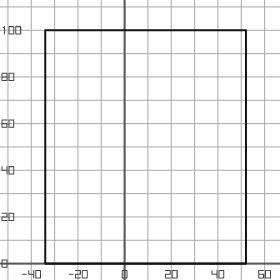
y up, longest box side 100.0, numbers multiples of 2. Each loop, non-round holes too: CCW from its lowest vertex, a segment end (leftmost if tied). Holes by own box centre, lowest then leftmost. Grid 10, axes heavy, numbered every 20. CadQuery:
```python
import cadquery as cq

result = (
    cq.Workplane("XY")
    .moveTo(-34.0, 0.0)
    .lineTo(52.0, 0.0)
    .lineTo(52.0, 100.0)
    .lineTo(-34.0, 100.0)
    .close()
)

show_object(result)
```